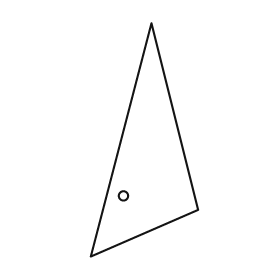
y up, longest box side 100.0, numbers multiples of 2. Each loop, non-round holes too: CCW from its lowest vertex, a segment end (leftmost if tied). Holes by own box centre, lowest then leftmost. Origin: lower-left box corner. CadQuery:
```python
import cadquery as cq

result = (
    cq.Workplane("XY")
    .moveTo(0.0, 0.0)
    .lineTo(46.0, 20.0)
    .lineTo(26.0, 100.0)
    .close()
    .moveTo(14.0, 26.0)
    .circle(2.0)
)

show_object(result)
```